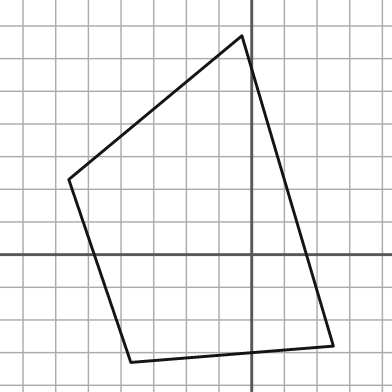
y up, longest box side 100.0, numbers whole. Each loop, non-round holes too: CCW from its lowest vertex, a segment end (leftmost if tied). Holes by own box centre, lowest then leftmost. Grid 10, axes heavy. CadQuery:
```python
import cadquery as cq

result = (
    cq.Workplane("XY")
    .moveTo(-37.0, -33.0)
    .lineTo(25.0, -28.0)
    .lineTo(-3.0, 67.0)
    .lineTo(-56.0, 23.0)
    .close()
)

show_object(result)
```